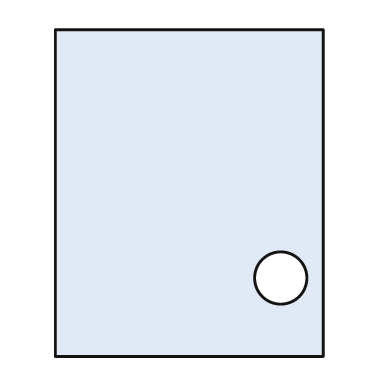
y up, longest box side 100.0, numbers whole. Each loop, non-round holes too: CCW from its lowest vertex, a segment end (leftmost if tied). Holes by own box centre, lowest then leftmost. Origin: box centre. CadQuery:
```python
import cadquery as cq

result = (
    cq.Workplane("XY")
    .moveTo(-41.0, -50.0)
    .lineTo(41.0, -50.0)
    .lineTo(41.0, 50.0)
    .lineTo(-41.0, 50.0)
    .close()
    .moveTo(28.0, -26.0)
    .circle(8.0)
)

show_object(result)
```